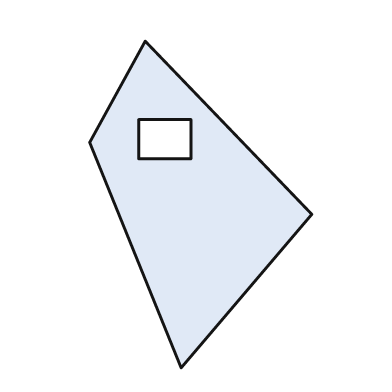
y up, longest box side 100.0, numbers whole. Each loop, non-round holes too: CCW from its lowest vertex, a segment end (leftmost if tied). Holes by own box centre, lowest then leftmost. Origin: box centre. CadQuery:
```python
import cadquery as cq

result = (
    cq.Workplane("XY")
    .moveTo(-6.0, -50.0)
    .lineTo(34.0, -3.0)
    .lineTo(-17.0, 50.0)
    .lineTo(-34.0, 19.0)
    .close()
    .moveTo(-19.0, 14.0)
    .lineTo(-3.0, 14.0)
    .lineTo(-3.0, 26.0)
    .lineTo(-19.0, 26.0)
    .close()
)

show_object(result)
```